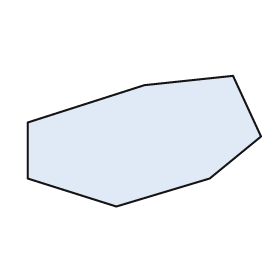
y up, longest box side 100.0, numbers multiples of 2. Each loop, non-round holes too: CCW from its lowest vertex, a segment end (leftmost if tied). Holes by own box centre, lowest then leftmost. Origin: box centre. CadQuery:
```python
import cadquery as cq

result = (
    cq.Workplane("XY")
    .moveTo(-12.0, -28.0)
    .lineTo(28.0, -16.0)
    .lineTo(50.0, 2.0)
    .lineTo(38.0, 28.0)
    .lineTo(0.0, 24.0)
    .lineTo(-50.0, 8.0)
    .lineTo(-50.0, -16.0)
    .close()
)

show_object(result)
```